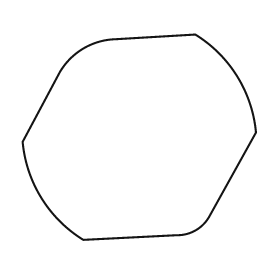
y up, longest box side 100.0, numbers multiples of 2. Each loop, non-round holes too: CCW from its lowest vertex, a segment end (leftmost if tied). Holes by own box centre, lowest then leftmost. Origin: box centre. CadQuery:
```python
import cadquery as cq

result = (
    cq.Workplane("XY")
    .moveTo(-24.0, -44.0)
    .lineTo(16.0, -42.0)
    .threePointArc((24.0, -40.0), (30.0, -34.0))
    .lineTo(50.0, 2.0)
    .threePointArc((42.0, 26.0), (24.0, 44.0))
    .lineTo(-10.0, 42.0)
    .threePointArc((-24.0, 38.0), (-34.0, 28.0))
    .lineTo(-50.0, -2.0)
    .threePointArc((-42.0, -26.0), (-24.0, -44.0))
    .close()
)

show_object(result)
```